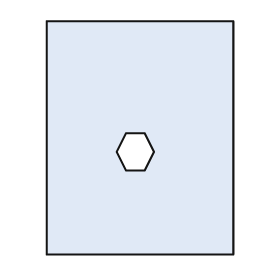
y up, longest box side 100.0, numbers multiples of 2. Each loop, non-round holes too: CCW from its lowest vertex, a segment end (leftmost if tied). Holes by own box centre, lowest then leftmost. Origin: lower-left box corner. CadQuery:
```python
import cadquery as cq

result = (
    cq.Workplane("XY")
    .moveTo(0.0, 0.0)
    .lineTo(80.0, 0.0)
    .lineTo(80.0, 100.0)
    .lineTo(0.0, 100.0)
    .close()
    .moveTo(34.0, 36.0)
    .lineTo(42.0, 36.0)
    .lineTo(46.0, 44.0)
    .lineTo(42.0, 52.0)
    .lineTo(34.0, 52.0)
    .lineTo(30.0, 44.0)
    .close()
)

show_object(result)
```